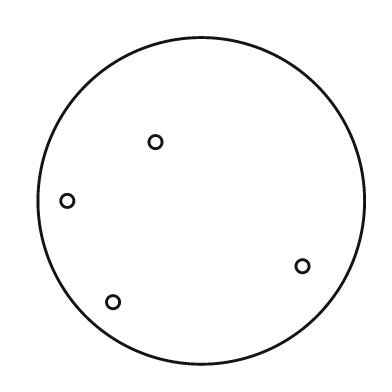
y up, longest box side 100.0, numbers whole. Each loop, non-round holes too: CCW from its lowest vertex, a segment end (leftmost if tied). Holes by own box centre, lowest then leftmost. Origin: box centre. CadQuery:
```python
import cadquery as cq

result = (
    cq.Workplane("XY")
    .moveTo(0.0, 0.0)
    .circle(50.0)
    .moveTo(-27.0, -31.0)
    .circle(2.0)
    .moveTo(31.0, -20.0)
    .circle(2.0)
    .moveTo(-41.0, 0.0)
    .circle(2.0)
    .moveTo(-14.0, 18.0)
    .circle(2.0)
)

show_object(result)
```